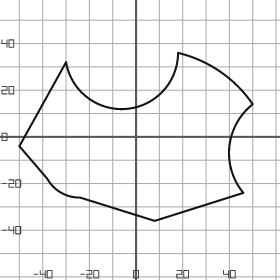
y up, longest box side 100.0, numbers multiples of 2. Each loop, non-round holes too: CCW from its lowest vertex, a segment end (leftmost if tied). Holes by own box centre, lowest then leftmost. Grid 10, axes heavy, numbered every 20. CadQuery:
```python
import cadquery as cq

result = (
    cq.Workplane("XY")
    .moveTo(8.0, -36.0)
    .lineTo(46.0, -24.0)
    .threePointArc((40.0, -4.0), (50.0, 14.0))
    .threePointArc((36.0, 28.0), (18.0, 36.0))
    .threePointArc((-4.0, 12.0), (-30.0, 32.0))
    .lineTo(-50.0, -4.0)
    .lineTo(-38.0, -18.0)
    .threePointArc((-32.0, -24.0), (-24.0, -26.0))
    .close()
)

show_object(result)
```